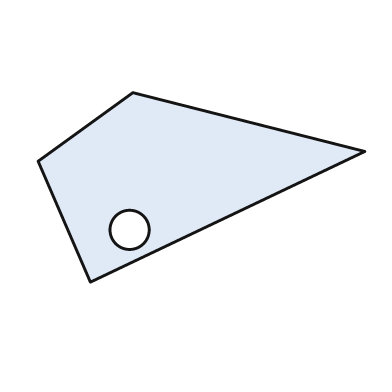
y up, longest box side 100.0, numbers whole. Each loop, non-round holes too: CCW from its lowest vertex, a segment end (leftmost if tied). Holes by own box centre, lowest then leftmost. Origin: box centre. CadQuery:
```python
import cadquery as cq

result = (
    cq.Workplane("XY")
    .moveTo(-34.0, -29.0)
    .lineTo(50.0, 11.0)
    .lineTo(-21.0, 29.0)
    .lineTo(-50.0, 8.0)
    .close()
    .moveTo(-22.0, -13.0)
    .circle(6.0)
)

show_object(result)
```